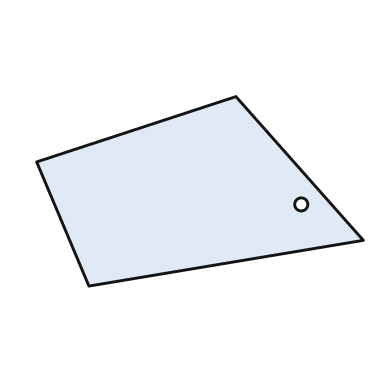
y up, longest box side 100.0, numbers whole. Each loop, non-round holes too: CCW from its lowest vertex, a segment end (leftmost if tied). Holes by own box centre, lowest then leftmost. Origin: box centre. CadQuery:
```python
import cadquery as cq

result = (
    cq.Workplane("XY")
    .moveTo(-34.0, -29.0)
    .lineTo(50.0, -15.0)
    .lineTo(11.0, 29.0)
    .lineTo(-50.0, 9.0)
    .close()
    .moveTo(31.0, -4.0)
    .circle(2.0)
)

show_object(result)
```